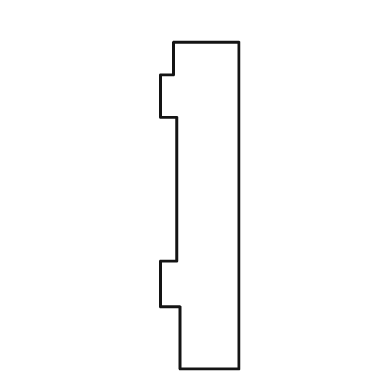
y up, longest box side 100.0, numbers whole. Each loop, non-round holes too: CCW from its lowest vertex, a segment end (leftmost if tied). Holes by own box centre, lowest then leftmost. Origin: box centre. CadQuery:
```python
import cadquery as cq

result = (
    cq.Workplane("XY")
    .moveTo(-6.0, -50.0)
    .lineTo(12.0, -50.0)
    .lineTo(12.0, 50.0)
    .lineTo(-8.0, 50.0)
    .lineTo(-8.0, 40.0)
    .lineTo(-12.0, 40.0)
    .lineTo(-12.0, 27.0)
    .lineTo(-7.0, 27.0)
    .lineTo(-7.0, -17.0)
    .lineTo(-12.0, -17.0)
    .lineTo(-12.0, -31.0)
    .lineTo(-6.0, -31.0)
    .close()
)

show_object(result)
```